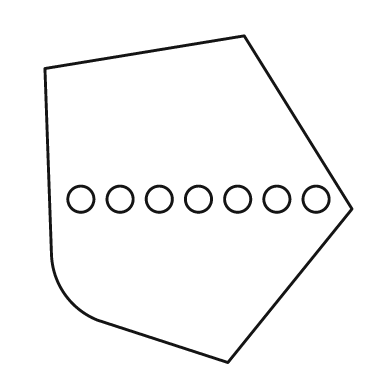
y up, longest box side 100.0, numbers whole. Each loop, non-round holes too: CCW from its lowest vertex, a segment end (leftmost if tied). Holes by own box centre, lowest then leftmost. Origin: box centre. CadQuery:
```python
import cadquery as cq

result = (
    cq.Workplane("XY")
    .moveTo(9.0, -50.0)
    .lineTo(47.0, -3.0)
    .lineTo(14.0, 50.0)
    .lineTo(-47.0, 40.0)
    .lineTo(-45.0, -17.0)
    .threePointArc((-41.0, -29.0), (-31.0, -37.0))
    .close()
    .moveTo(-36.0, 0.0)
    .circle(4.0)
    .moveTo(-24.0, 0.0)
    .circle(4.0)
    .moveTo(-12.0, 0.0)
    .circle(4.0)
    .moveTo(0.0, 0.0)
    .circle(4.0)
    .moveTo(12.0, 0.0)
    .circle(4.0)
    .moveTo(24.0, 0.0)
    .circle(4.0)
    .moveTo(36.0, 0.0)
    .circle(4.0)
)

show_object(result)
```